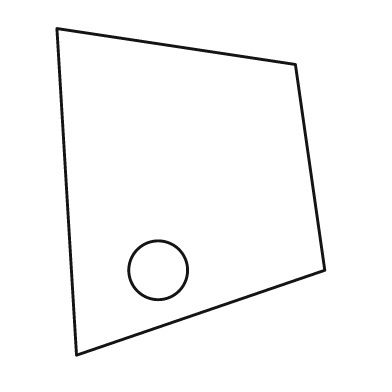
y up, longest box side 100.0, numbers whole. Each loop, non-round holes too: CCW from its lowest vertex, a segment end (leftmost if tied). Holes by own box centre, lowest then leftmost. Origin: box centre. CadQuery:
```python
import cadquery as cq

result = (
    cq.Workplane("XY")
    .moveTo(-35.0, -50.0)
    .lineTo(41.0, -24.0)
    .lineTo(32.0, 39.0)
    .lineTo(-41.0, 50.0)
    .close()
    .moveTo(-10.0, -24.0)
    .circle(9.0)
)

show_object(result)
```